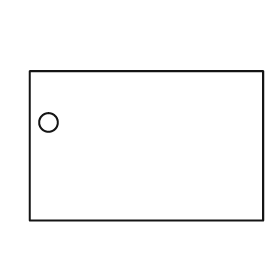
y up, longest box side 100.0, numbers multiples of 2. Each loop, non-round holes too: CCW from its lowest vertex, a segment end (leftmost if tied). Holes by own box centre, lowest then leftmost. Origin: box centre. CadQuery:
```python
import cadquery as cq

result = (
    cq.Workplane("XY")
    .moveTo(-50.0, -32.0)
    .lineTo(50.0, -32.0)
    .lineTo(50.0, 32.0)
    .lineTo(-50.0, 32.0)
    .close()
    .moveTo(-42.0, 10.0)
    .circle(4.0)
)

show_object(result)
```